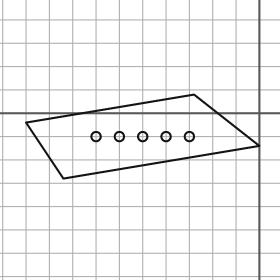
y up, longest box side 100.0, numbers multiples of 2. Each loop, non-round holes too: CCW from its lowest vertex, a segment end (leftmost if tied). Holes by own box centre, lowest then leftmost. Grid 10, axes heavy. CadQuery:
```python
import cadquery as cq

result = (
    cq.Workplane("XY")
    .moveTo(-84.0, -28.0)
    .lineTo(0.0, -14.0)
    .lineTo(-28.0, 8.0)
    .lineTo(-100.0, -4.0)
    .close()
    .moveTo(-70.0, -10.0)
    .circle(2.0)
    .moveTo(-60.0, -10.0)
    .circle(2.0)
    .moveTo(-50.0, -10.0)
    .circle(2.0)
    .moveTo(-40.0, -10.0)
    .circle(2.0)
    .moveTo(-30.0, -10.0)
    .circle(2.0)
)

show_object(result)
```